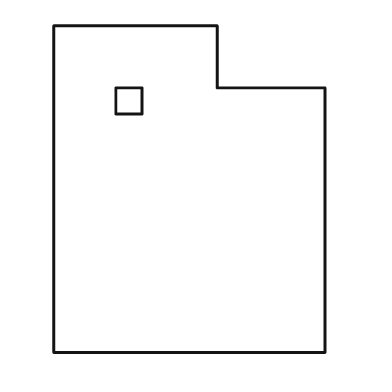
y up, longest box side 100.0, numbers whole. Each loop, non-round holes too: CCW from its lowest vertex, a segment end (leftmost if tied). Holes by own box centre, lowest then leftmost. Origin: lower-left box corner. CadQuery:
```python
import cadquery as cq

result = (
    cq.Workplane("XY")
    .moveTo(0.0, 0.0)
    .lineTo(83.0, 0.0)
    .lineTo(83.0, 81.0)
    .lineTo(50.0, 81.0)
    .lineTo(50.0, 100.0)
    .lineTo(0.0, 100.0)
    .close()
    .moveTo(19.0, 73.0)
    .lineTo(27.0, 73.0)
    .lineTo(27.0, 81.0)
    .lineTo(19.0, 81.0)
    .close()
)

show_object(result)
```